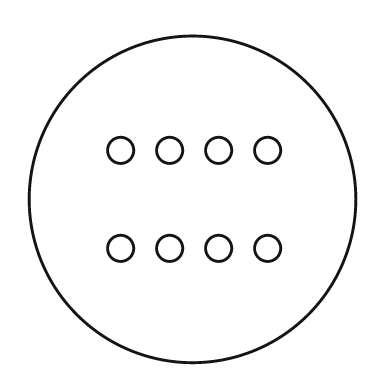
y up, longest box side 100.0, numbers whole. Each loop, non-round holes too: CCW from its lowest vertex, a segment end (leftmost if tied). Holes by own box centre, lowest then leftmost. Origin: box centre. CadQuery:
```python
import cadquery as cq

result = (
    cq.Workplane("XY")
    .moveTo(0.0, 0.0)
    .circle(50.0)
    .moveTo(-22.0, -15.0)
    .circle(4.0)
    .moveTo(-7.0, -15.0)
    .circle(4.0)
    .moveTo(8.0, -15.0)
    .circle(4.0)
    .moveTo(23.0, -15.0)
    .circle(4.0)
    .moveTo(-22.0, 15.0)
    .circle(4.0)
    .moveTo(-7.0, 15.0)
    .circle(4.0)
    .moveTo(8.0, 15.0)
    .circle(4.0)
    .moveTo(23.0, 15.0)
    .circle(4.0)
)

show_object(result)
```